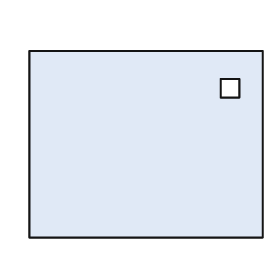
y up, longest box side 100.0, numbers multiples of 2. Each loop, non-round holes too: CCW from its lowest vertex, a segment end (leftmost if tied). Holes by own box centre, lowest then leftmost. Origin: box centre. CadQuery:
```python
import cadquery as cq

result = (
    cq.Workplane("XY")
    .moveTo(-50.0, -40.0)
    .lineTo(50.0, -40.0)
    .lineTo(50.0, 40.0)
    .lineTo(-50.0, 40.0)
    .close()
    .moveTo(32.0, 20.0)
    .lineTo(40.0, 20.0)
    .lineTo(40.0, 28.0)
    .lineTo(32.0, 28.0)
    .close()
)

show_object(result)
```